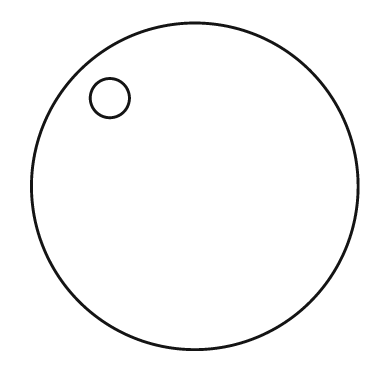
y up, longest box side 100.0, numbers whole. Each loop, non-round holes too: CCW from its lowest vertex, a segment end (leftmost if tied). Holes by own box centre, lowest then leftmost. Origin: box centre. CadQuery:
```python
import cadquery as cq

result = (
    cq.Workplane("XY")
    .moveTo(0.0, 0.0)
    .circle(50.0)
    .moveTo(-26.0, 27.0)
    .circle(6.0)
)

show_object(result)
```